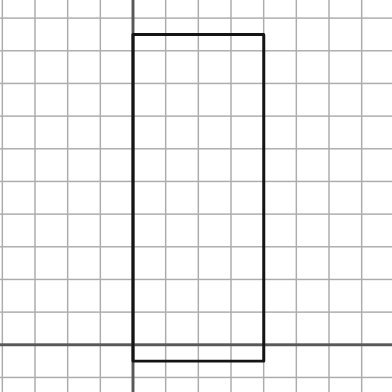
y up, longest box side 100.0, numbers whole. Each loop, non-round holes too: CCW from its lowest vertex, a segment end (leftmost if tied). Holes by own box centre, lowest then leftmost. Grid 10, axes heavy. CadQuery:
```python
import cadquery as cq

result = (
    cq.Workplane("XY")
    .moveTo(0.0, -5.0)
    .lineTo(40.0, -5.0)
    .lineTo(40.0, 95.0)
    .lineTo(0.0, 95.0)
    .close()
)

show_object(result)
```